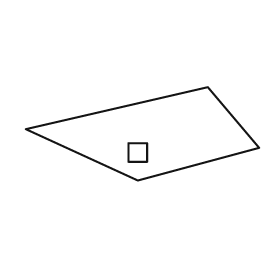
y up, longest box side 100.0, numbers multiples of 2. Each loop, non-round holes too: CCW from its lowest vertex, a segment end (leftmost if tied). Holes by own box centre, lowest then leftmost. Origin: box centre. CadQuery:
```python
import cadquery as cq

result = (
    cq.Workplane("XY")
    .moveTo(-2.0, -20.0)
    .lineTo(50.0, -6.0)
    .lineTo(28.0, 20.0)
    .lineTo(-50.0, 2.0)
    .close()
    .moveTo(-6.0, -12.0)
    .lineTo(2.0, -12.0)
    .lineTo(2.0, -4.0)
    .lineTo(-6.0, -4.0)
    .close()
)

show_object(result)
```